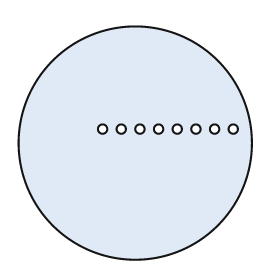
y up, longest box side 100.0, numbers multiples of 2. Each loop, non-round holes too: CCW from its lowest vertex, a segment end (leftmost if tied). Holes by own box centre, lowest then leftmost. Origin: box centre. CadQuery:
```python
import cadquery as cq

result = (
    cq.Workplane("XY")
    .moveTo(0.0, 0.0)
    .circle(50.0)
    .moveTo(-14.0, 6.0)
    .circle(2.0)
    .moveTo(-6.0, 6.0)
    .circle(2.0)
    .moveTo(2.0, 6.0)
    .circle(2.0)
    .moveTo(10.0, 6.0)
    .circle(2.0)
    .moveTo(18.0, 6.0)
    .circle(2.0)
    .moveTo(26.0, 6.0)
    .circle(2.0)
    .moveTo(34.0, 6.0)
    .circle(2.0)
    .moveTo(42.0, 6.0)
    .circle(2.0)
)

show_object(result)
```